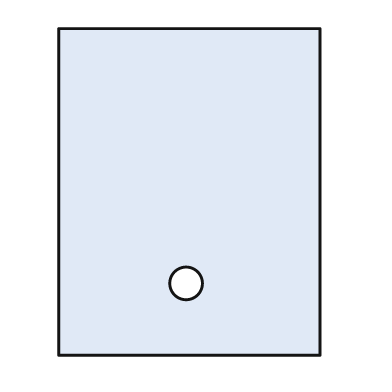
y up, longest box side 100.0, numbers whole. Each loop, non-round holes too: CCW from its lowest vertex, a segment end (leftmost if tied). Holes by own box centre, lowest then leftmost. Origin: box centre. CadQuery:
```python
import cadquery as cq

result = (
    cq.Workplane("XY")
    .moveTo(-40.0, -50.0)
    .lineTo(40.0, -50.0)
    .lineTo(40.0, 50.0)
    .lineTo(-40.0, 50.0)
    .close()
    .moveTo(-1.0, -28.0)
    .circle(5.0)
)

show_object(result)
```